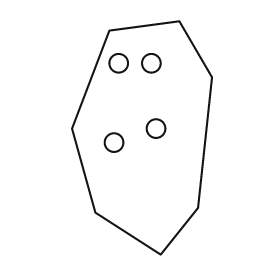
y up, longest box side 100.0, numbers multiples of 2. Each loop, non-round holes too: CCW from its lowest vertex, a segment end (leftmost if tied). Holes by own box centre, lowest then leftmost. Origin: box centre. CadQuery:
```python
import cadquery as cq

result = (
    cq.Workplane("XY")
    .moveTo(8.0, -50.0)
    .lineTo(24.0, -30.0)
    .lineTo(30.0, 26.0)
    .lineTo(16.0, 50.0)
    .lineTo(-14.0, 46.0)
    .lineTo(-30.0, 4.0)
    .lineTo(-20.0, -32.0)
    .close()
    .moveTo(-12.0, -2.0)
    .circle(4.0)
    .moveTo(6.0, 4.0)
    .circle(4.0)
    .moveTo(-10.0, 32.0)
    .circle(4.0)
    .moveTo(4.0, 32.0)
    .circle(4.0)
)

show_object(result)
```